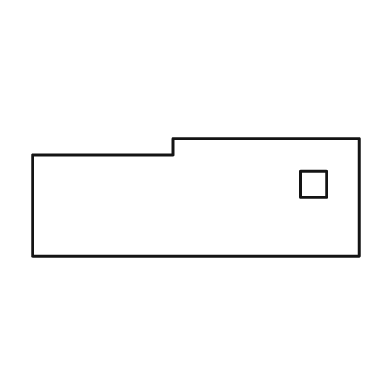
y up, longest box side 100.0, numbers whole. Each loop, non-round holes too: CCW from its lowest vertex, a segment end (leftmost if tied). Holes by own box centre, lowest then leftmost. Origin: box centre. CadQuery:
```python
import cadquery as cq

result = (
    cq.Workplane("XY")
    .moveTo(-50.0, -18.0)
    .lineTo(50.0, -18.0)
    .lineTo(50.0, 18.0)
    .lineTo(-7.0, 18.0)
    .lineTo(-7.0, 13.0)
    .lineTo(-50.0, 13.0)
    .close()
    .moveTo(32.0, 0.0)
    .lineTo(40.0, 0.0)
    .lineTo(40.0, 8.0)
    .lineTo(32.0, 8.0)
    .close()
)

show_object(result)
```